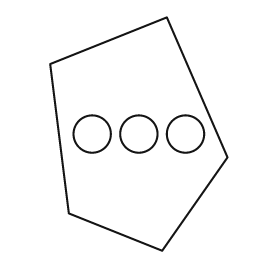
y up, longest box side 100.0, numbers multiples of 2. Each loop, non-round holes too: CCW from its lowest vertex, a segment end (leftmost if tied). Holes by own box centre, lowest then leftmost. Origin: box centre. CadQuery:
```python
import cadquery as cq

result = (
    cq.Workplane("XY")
    .moveTo(10.0, -50.0)
    .lineTo(38.0, -10.0)
    .lineTo(12.0, 50.0)
    .lineTo(-38.0, 30.0)
    .lineTo(-30.0, -34.0)
    .close()
    .moveTo(-20.0, 0.0)
    .circle(8.0)
    .moveTo(0.0, 0.0)
    .circle(8.0)
    .moveTo(20.0, 0.0)
    .circle(8.0)
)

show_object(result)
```